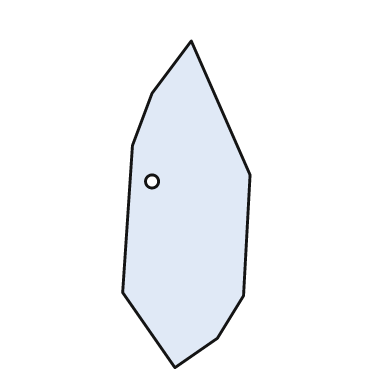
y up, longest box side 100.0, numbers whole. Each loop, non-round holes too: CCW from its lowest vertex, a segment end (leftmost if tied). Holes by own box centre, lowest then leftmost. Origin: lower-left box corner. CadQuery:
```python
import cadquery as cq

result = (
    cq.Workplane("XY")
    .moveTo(16.0, 0.0)
    .lineTo(29.0, 9.0)
    .lineTo(37.0, 22.0)
    .lineTo(39.0, 59.0)
    .lineTo(21.0, 100.0)
    .lineTo(9.0, 84.0)
    .lineTo(3.0, 68.0)
    .lineTo(0.0, 23.0)
    .close()
    .moveTo(9.0, 57.0)
    .circle(2.0)
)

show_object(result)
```